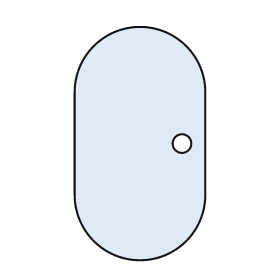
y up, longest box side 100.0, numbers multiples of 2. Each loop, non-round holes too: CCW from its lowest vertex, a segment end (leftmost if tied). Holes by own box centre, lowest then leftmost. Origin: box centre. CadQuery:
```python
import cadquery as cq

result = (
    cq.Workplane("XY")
    .moveTo(-28.0, -22.0)
    .threePointArc((0.0, -50.0), (28.0, -22.0))
    .lineTo(28.0, 22.0)
    .threePointArc((0.0, 50.0), (-28.0, 22.0))
    .close()
    .moveTo(18.0, 0.0)
    .circle(4.0)
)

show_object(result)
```